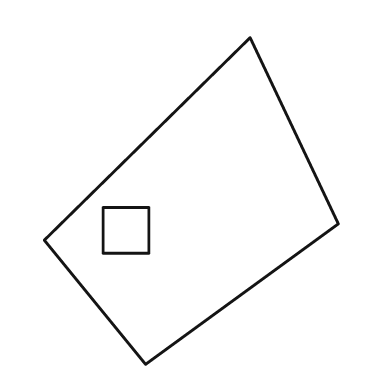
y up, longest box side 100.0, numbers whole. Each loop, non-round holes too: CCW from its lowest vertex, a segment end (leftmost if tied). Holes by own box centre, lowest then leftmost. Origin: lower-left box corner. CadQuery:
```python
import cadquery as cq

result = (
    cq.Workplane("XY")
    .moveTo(31.0, 0.0)
    .lineTo(90.0, 43.0)
    .lineTo(63.0, 100.0)
    .lineTo(0.0, 38.0)
    .close()
    .moveTo(18.0, 34.0)
    .lineTo(32.0, 34.0)
    .lineTo(32.0, 48.0)
    .lineTo(18.0, 48.0)
    .close()
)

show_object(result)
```